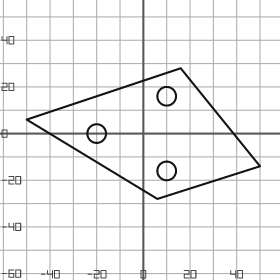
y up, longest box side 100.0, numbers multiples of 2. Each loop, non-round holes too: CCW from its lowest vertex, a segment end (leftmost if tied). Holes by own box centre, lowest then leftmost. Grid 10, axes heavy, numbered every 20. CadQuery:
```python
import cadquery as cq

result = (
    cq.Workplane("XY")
    .moveTo(6.0, -28.0)
    .lineTo(50.0, -14.0)
    .lineTo(16.0, 28.0)
    .lineTo(-50.0, 6.0)
    .close()
    .moveTo(10.0, -16.0)
    .circle(4.0)
    .moveTo(-20.0, 0.0)
    .circle(4.0)
    .moveTo(10.0, 16.0)
    .circle(4.0)
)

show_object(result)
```